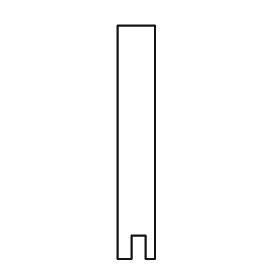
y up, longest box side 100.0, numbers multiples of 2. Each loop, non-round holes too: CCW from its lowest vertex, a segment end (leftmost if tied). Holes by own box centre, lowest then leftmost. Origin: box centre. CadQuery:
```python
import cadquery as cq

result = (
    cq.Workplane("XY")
    .moveTo(-8.0, -50.0)
    .lineTo(-2.0, -50.0)
    .lineTo(-2.0, -40.0)
    .lineTo(4.0, -40.0)
    .lineTo(4.0, -50.0)
    .lineTo(8.0, -50.0)
    .lineTo(8.0, 50.0)
    .lineTo(-8.0, 50.0)
    .close()
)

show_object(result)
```